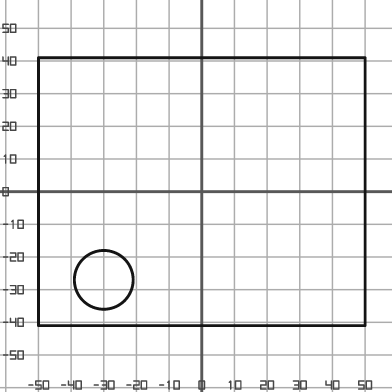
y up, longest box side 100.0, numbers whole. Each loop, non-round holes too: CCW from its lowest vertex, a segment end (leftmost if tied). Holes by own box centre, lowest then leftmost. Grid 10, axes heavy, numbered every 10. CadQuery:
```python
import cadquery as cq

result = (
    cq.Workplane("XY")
    .moveTo(-50.0, -41.0)
    .lineTo(50.0, -41.0)
    .lineTo(50.0, 41.0)
    .lineTo(-50.0, 41.0)
    .close()
    .moveTo(-30.0, -27.0)
    .circle(9.0)
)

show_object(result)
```